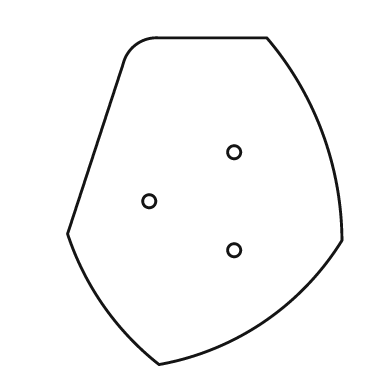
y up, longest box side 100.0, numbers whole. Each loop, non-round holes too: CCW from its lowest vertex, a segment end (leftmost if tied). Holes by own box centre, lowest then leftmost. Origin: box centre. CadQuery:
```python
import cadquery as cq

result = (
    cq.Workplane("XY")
    .moveTo(-14.0, -50.0)
    .threePointArc((18.0, -37.0), (42.0, -12.0))
    .threePointArc((36.0, 21.0), (19.0, 50.0))
    .lineTo(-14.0, 50.0)
    .threePointArc((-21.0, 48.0), (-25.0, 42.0))
    .lineTo(-42.0, -10.0)
    .threePointArc((-31.0, -32.0), (-14.0, -50.0))
    .close()
    .moveTo(9.0, -15.0)
    .circle(2.0)
    .moveTo(-17.0, 0.0)
    .circle(2.0)
    .moveTo(9.0, 15.0)
    .circle(2.0)
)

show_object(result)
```